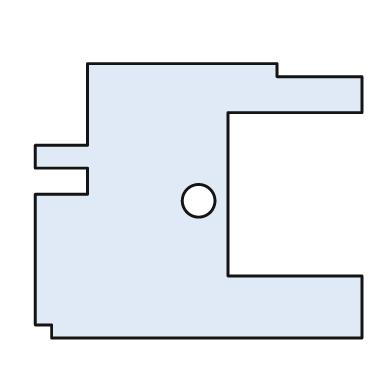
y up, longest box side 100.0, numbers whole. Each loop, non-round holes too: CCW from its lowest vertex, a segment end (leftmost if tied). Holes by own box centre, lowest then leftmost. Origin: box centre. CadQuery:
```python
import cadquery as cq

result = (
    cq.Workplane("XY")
    .moveTo(-45.0, -42.0)
    .lineTo(50.0, -42.0)
    .lineTo(50.0, -23.0)
    .lineTo(9.0, -23.0)
    .lineTo(9.0, 27.0)
    .lineTo(50.0, 27.0)
    .lineTo(50.0, 38.0)
    .lineTo(24.0, 38.0)
    .lineTo(24.0, 42.0)
    .lineTo(-34.0, 42.0)
    .lineTo(-34.0, 17.0)
    .lineTo(-50.0, 17.0)
    .lineTo(-50.0, 10.0)
    .lineTo(-34.0, 10.0)
    .lineTo(-34.0, 2.0)
    .lineTo(-50.0, 2.0)
    .lineTo(-50.0, -38.0)
    .lineTo(-45.0, -38.0)
    .close()
    .moveTo(0.0, 0.0)
    .circle(5.0)
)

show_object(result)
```